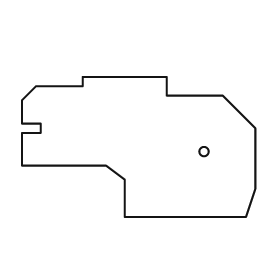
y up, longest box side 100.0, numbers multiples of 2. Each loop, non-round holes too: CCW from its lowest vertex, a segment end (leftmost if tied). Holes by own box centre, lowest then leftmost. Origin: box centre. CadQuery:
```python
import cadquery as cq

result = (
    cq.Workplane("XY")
    .moveTo(-6.0, -30.0)
    .lineTo(46.0, -30.0)
    .lineTo(50.0, -18.0)
    .lineTo(50.0, 8.0)
    .lineTo(36.0, 22.0)
    .lineTo(12.0, 22.0)
    .lineTo(12.0, 30.0)
    .lineTo(-24.0, 30.0)
    .lineTo(-24.0, 26.0)
    .lineTo(-44.0, 26.0)
    .lineTo(-50.0, 20.0)
    .lineTo(-50.0, 10.0)
    .lineTo(-42.0, 10.0)
    .lineTo(-42.0, 6.0)
    .lineTo(-50.0, 6.0)
    .lineTo(-50.0, -8.0)
    .lineTo(-14.0, -8.0)
    .lineTo(-6.0, -14.0)
    .close()
    .moveTo(28.0, -2.0)
    .circle(2.0)
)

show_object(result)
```